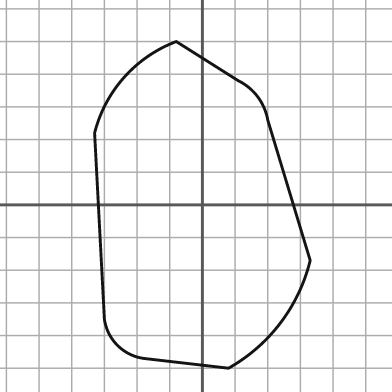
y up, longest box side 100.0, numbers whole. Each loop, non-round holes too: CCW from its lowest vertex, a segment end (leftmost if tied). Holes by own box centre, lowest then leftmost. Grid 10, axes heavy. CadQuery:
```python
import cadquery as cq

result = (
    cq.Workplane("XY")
    .moveTo(8.0, -50.0)
    .threePointArc((24.0, -36.0), (33.0, -17.0))
    .lineTo(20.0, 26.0)
    .threePointArc((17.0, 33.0), (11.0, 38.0))
    .lineTo(-8.0, 50.0)
    .threePointArc((-24.0, 39.0), (-33.0, 22.0))
    .lineTo(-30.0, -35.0)
    .threePointArc((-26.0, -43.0), (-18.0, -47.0))
    .close()
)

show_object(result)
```